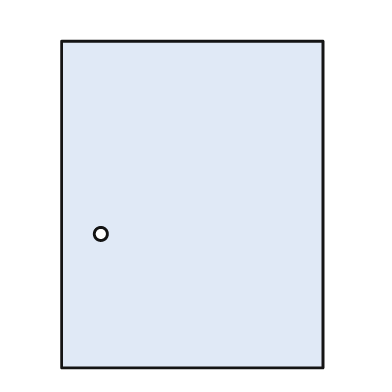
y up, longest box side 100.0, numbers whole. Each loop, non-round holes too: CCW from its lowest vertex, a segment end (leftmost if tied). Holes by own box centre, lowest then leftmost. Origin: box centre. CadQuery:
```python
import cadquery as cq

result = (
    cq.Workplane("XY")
    .moveTo(-40.0, -50.0)
    .lineTo(40.0, -50.0)
    .lineTo(40.0, 50.0)
    .lineTo(-40.0, 50.0)
    .close()
    .moveTo(-28.0, -9.0)
    .circle(2.0)
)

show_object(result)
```